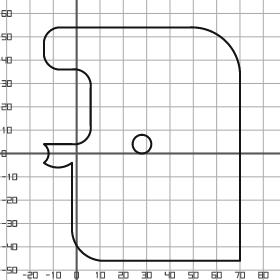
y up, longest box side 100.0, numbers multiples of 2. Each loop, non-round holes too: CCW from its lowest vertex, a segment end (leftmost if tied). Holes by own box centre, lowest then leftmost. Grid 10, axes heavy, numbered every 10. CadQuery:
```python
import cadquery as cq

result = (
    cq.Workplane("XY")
    .moveTo(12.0, -46.0)
    .lineTo(70.0, -46.0)
    .lineTo(70.0, 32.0)
    .threePointArc((64.0, 48.0), (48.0, 54.0))
    .lineTo(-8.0, 54.0)
    .threePointArc((-12.0, 52.0), (-14.0, 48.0))
    .lineTo(-14.0, 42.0)
    .threePointArc((-12.0, 38.0), (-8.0, 36.0))
    .lineTo(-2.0, 36.0)
    .threePointArc((4.0, 34.0), (6.0, 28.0))
    .lineTo(6.0, 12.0)
    .threePointArc((4.0, 6.0), (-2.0, 4.0))
    .lineTo(-14.0, 4.0)
    .threePointArc((-12.0, 0.0), (-14.0, -4.0))
    .threePointArc((-8.0, -6.0), (-2.0, -4.0))
    .lineTo(-2.0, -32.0)
    .threePointArc((2.0, -42.0), (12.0, -46.0))
    .close()
    .moveTo(28.0, 4.0)
    .circle(4.0)
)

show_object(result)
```